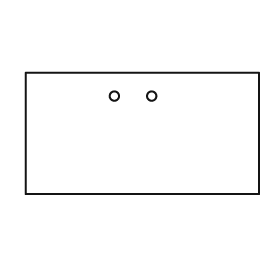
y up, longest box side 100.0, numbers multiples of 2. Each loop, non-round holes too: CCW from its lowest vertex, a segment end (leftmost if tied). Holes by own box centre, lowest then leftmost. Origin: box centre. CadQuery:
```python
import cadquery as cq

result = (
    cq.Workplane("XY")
    .moveTo(-50.0, -26.0)
    .lineTo(50.0, -26.0)
    .lineTo(50.0, 26.0)
    .lineTo(-50.0, 26.0)
    .close()
    .moveTo(-12.0, 16.0)
    .circle(2.0)
    .moveTo(4.0, 16.0)
    .circle(2.0)
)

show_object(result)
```